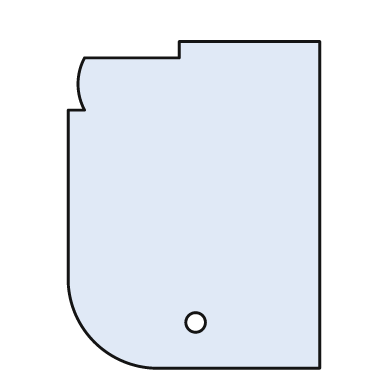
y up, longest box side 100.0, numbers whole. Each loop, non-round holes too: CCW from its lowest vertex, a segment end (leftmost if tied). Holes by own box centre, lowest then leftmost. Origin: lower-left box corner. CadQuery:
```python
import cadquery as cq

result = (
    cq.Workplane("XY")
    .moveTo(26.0, 0.0)
    .lineTo(77.0, 0.0)
    .lineTo(77.0, 100.0)
    .lineTo(34.0, 100.0)
    .lineTo(34.0, 95.0)
    .lineTo(5.0, 95.0)
    .threePointArc((3.0, 87.0), (5.0, 79.0))
    .lineTo(0.0, 79.0)
    .lineTo(0.0, 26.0)
    .threePointArc((8.0, 8.0), (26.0, 0.0))
    .close()
    .moveTo(39.0, 14.0)
    .circle(3.0)
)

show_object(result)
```